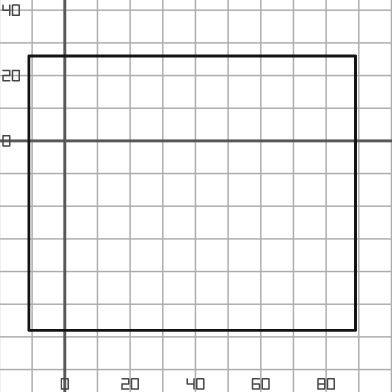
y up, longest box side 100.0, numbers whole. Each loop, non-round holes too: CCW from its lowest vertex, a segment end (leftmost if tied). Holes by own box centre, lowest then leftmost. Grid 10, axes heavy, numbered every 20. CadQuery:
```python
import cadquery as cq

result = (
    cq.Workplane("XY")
    .moveTo(-11.0, -58.0)
    .lineTo(89.0, -58.0)
    .lineTo(89.0, 26.0)
    .lineTo(-11.0, 26.0)
    .close()
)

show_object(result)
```